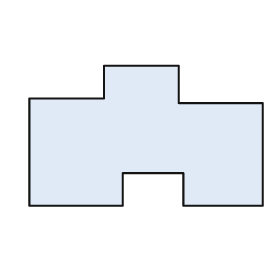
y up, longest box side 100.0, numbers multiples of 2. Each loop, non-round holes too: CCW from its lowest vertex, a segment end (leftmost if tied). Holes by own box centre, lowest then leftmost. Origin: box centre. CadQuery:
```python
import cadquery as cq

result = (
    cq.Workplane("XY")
    .moveTo(-50.0, -30.0)
    .lineTo(-10.0, -30.0)
    .lineTo(-10.0, -16.0)
    .lineTo(16.0, -16.0)
    .lineTo(16.0, -30.0)
    .lineTo(50.0, -30.0)
    .lineTo(50.0, 14.0)
    .lineTo(14.0, 14.0)
    .lineTo(14.0, 30.0)
    .lineTo(-18.0, 30.0)
    .lineTo(-18.0, 16.0)
    .lineTo(-50.0, 16.0)
    .close()
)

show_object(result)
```